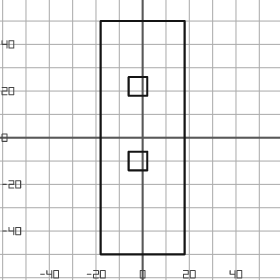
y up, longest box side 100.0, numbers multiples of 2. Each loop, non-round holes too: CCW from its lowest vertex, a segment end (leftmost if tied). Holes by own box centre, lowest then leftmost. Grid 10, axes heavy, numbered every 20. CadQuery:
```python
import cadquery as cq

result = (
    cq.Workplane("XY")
    .moveTo(-18.0, -50.0)
    .lineTo(18.0, -50.0)
    .lineTo(18.0, 50.0)
    .lineTo(-18.0, 50.0)
    .close()
    .moveTo(-6.0, -14.0)
    .lineTo(2.0, -14.0)
    .lineTo(2.0, -6.0)
    .lineTo(-6.0, -6.0)
    .close()
    .moveTo(-6.0, 18.0)
    .lineTo(2.0, 18.0)
    .lineTo(2.0, 26.0)
    .lineTo(-6.0, 26.0)
    .close()
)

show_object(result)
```